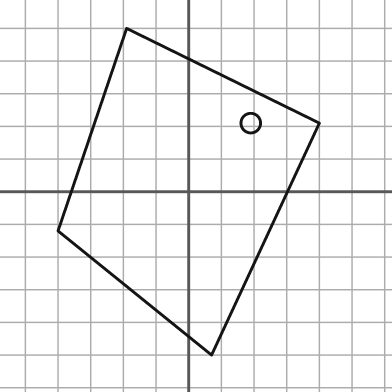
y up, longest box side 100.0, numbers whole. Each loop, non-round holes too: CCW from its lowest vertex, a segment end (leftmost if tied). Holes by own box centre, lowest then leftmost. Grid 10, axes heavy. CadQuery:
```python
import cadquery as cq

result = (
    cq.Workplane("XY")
    .moveTo(7.0, -50.0)
    .lineTo(40.0, 21.0)
    .lineTo(-19.0, 50.0)
    .lineTo(-40.0, -12.0)
    .close()
    .moveTo(19.0, 21.0)
    .circle(3.0)
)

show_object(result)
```